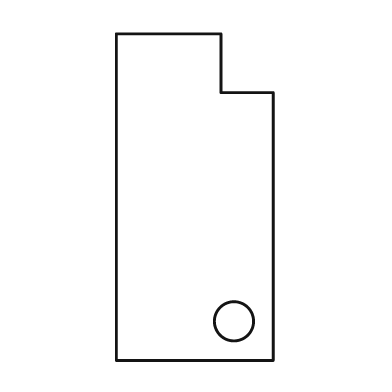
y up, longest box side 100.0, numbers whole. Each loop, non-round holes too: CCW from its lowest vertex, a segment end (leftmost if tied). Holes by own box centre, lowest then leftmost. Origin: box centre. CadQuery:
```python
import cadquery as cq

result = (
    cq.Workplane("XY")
    .moveTo(-24.0, -50.0)
    .lineTo(24.0, -50.0)
    .lineTo(24.0, 32.0)
    .lineTo(8.0, 32.0)
    .lineTo(8.0, 50.0)
    .lineTo(-24.0, 50.0)
    .close()
    .moveTo(12.0, -38.0)
    .circle(6.0)
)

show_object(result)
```